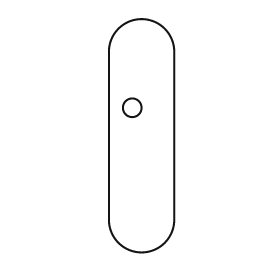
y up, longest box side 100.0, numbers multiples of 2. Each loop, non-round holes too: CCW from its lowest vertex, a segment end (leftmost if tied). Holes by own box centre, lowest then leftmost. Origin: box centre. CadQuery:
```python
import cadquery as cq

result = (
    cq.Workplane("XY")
    .moveTo(-14.0, -36.0)
    .threePointArc((0.0, -50.0), (14.0, -36.0))
    .lineTo(14.0, 36.0)
    .threePointArc((0.0, 50.0), (-14.0, 36.0))
    .close()
    .moveTo(-4.0, 12.0)
    .circle(4.0)
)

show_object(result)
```